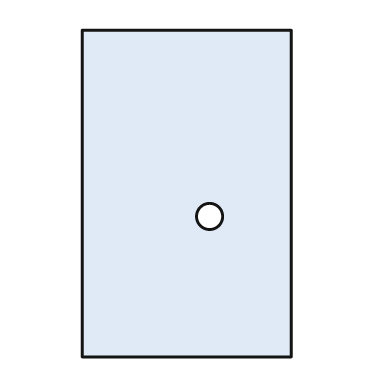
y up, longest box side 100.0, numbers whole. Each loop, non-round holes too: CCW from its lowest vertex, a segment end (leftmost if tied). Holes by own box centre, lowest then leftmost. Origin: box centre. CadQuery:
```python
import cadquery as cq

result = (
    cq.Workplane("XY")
    .moveTo(-32.0, -50.0)
    .lineTo(32.0, -50.0)
    .lineTo(32.0, 50.0)
    .lineTo(-32.0, 50.0)
    .close()
    .moveTo(7.0, -7.0)
    .circle(4.0)
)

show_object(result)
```